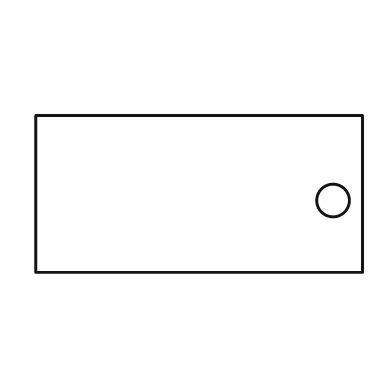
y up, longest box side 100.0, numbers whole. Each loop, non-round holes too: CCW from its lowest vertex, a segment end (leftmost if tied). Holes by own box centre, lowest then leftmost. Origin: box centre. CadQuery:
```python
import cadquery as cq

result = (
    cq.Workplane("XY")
    .moveTo(-50.0, -24.0)
    .lineTo(50.0, -24.0)
    .lineTo(50.0, 24.0)
    .lineTo(-50.0, 24.0)
    .close()
    .moveTo(41.0, -2.0)
    .circle(5.0)
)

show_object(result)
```